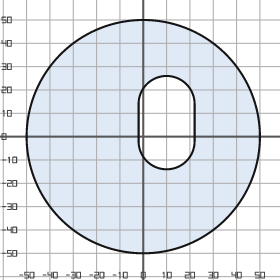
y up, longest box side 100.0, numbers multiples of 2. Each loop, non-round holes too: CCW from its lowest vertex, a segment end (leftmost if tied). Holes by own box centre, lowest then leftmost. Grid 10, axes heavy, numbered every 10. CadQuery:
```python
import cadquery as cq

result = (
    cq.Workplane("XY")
    .moveTo(0.0, 0.0)
    .circle(50.0)
    .moveTo(-2.0, -2.0)
    .threePointArc((10.0, -14.0), (22.0, -2.0))
    .lineTo(22.0, 14.0)
    .threePointArc((10.0, 26.0), (-2.0, 14.0))
    .close()
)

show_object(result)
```